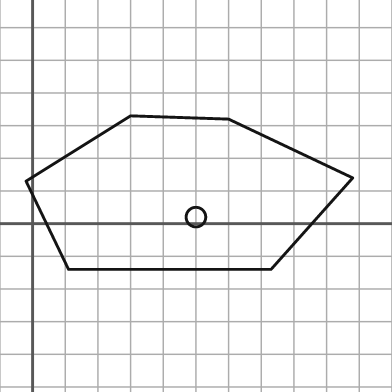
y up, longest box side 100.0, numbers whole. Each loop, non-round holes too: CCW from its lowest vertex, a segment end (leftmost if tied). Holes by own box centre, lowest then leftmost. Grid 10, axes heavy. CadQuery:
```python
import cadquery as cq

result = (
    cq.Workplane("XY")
    .moveTo(11.0, -14.0)
    .lineTo(73.0, -14.0)
    .lineTo(98.0, 14.0)
    .lineTo(60.0, 32.0)
    .lineTo(30.0, 33.0)
    .lineTo(-2.0, 13.0)
    .close()
    .moveTo(50.0, 2.0)
    .circle(3.0)
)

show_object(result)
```